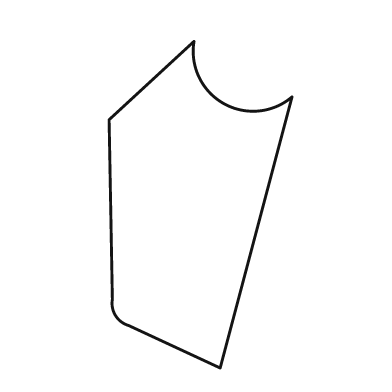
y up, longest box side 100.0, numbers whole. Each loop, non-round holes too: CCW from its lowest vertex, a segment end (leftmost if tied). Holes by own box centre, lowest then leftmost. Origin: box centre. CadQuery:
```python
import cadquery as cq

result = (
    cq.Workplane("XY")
    .moveTo(6.0, -50.0)
    .lineTo(28.0, 33.0)
    .threePointArc((7.0, 31.0), (-2.0, 50.0))
    .lineTo(-28.0, 26.0)
    .lineTo(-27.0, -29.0)
    .threePointArc((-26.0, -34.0), (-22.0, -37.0))
    .close()
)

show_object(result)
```